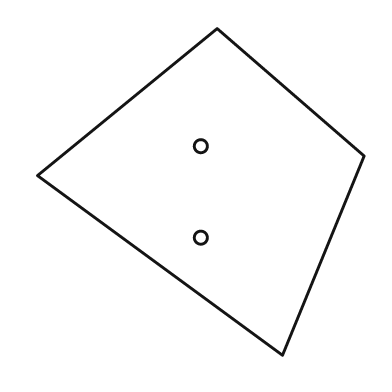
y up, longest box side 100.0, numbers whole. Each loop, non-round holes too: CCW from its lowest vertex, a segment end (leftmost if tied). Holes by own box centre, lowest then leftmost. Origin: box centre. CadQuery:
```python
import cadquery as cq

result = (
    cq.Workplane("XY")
    .moveTo(25.0, -50.0)
    .lineTo(50.0, 11.0)
    .lineTo(5.0, 50.0)
    .lineTo(-50.0, 5.0)
    .close()
    .moveTo(0.0, -14.0)
    .circle(2.0)
    .moveTo(0.0, 14.0)
    .circle(2.0)
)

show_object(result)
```